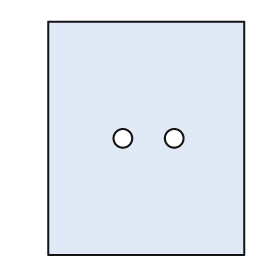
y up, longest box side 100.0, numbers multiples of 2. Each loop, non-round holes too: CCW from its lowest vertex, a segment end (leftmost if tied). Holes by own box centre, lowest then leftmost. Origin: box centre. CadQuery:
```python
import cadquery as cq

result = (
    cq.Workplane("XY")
    .moveTo(-42.0, -50.0)
    .lineTo(42.0, -50.0)
    .lineTo(42.0, 50.0)
    .lineTo(-42.0, 50.0)
    .close()
    .moveTo(-10.0, 0.0)
    .circle(4.0)
    .moveTo(12.0, 0.0)
    .circle(4.0)
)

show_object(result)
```